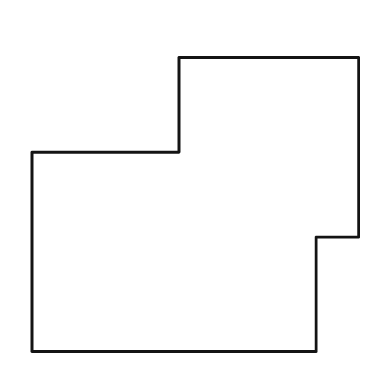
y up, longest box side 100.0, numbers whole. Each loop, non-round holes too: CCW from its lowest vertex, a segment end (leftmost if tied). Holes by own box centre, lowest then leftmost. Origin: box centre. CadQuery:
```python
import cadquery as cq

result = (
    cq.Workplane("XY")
    .moveTo(-50.0, -45.0)
    .lineTo(37.0, -45.0)
    .lineTo(37.0, -10.0)
    .lineTo(50.0, -10.0)
    .lineTo(50.0, 45.0)
    .lineTo(-5.0, 45.0)
    .lineTo(-5.0, 16.0)
    .lineTo(-50.0, 16.0)
    .close()
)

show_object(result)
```